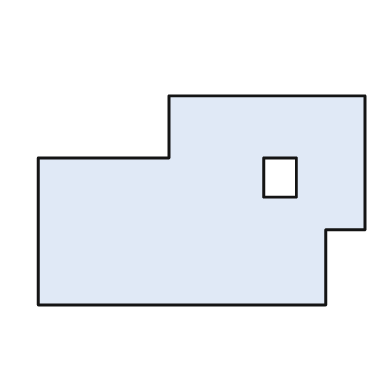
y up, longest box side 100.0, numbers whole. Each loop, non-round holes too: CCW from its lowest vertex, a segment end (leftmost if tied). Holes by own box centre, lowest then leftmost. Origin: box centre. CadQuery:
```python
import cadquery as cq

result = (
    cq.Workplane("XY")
    .moveTo(-50.0, -32.0)
    .lineTo(38.0, -32.0)
    .lineTo(38.0, -9.0)
    .lineTo(50.0, -9.0)
    .lineTo(50.0, 32.0)
    .lineTo(-10.0, 32.0)
    .lineTo(-10.0, 13.0)
    .lineTo(-50.0, 13.0)
    .close()
    .moveTo(19.0, 1.0)
    .lineTo(29.0, 1.0)
    .lineTo(29.0, 13.0)
    .lineTo(19.0, 13.0)
    .close()
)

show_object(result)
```